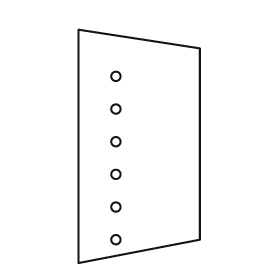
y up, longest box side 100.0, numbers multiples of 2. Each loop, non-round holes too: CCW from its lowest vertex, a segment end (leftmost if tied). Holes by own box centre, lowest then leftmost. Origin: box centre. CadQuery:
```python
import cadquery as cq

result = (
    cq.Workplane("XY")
    .moveTo(-26.0, -50.0)
    .lineTo(26.0, -40.0)
    .lineTo(26.0, 42.0)
    .lineTo(-26.0, 50.0)
    .close()
    .moveTo(-10.0, -40.0)
    .circle(2.0)
    .moveTo(-10.0, -26.0)
    .circle(2.0)
    .moveTo(-10.0, -12.0)
    .circle(2.0)
    .moveTo(-10.0, 2.0)
    .circle(2.0)
    .moveTo(-10.0, 16.0)
    .circle(2.0)
    .moveTo(-10.0, 30.0)
    .circle(2.0)
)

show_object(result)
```